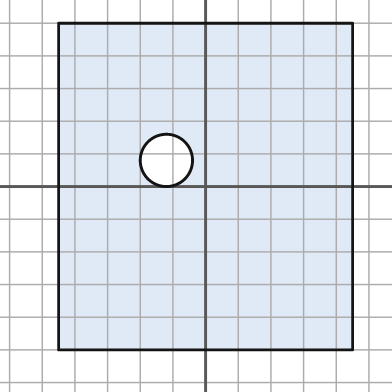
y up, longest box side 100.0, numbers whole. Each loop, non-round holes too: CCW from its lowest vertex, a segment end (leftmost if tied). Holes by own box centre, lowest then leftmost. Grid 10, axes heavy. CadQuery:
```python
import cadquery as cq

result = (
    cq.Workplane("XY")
    .moveTo(-45.0, -50.0)
    .lineTo(45.0, -50.0)
    .lineTo(45.0, 50.0)
    .lineTo(-45.0, 50.0)
    .close()
    .moveTo(-12.0, 8.0)
    .circle(8.0)
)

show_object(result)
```